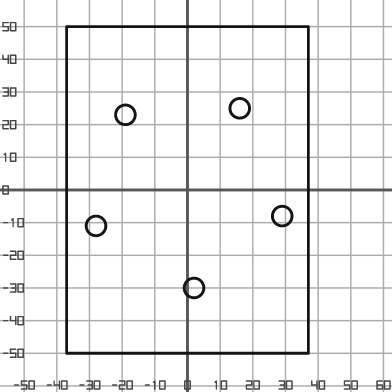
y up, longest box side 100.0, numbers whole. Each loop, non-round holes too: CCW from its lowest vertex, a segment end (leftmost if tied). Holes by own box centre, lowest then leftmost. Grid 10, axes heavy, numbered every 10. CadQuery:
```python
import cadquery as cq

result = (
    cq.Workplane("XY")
    .moveTo(-37.0, -50.0)
    .lineTo(37.0, -50.0)
    .lineTo(37.0, 50.0)
    .lineTo(-37.0, 50.0)
    .close()
    .moveTo(2.0, -30.0)
    .circle(3.0)
    .moveTo(-28.0, -11.0)
    .circle(3.0)
    .moveTo(29.0, -8.0)
    .circle(3.0)
    .moveTo(-19.0, 23.0)
    .circle(3.0)
    .moveTo(16.0, 25.0)
    .circle(3.0)
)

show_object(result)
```